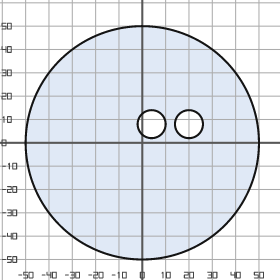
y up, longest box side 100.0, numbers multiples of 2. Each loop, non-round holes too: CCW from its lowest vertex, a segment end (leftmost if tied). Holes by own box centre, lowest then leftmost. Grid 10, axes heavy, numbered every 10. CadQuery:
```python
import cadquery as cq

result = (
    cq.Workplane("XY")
    .moveTo(0.0, 0.0)
    .circle(50.0)
    .moveTo(4.0, 8.0)
    .circle(6.0)
    .moveTo(20.0, 8.0)
    .circle(6.0)
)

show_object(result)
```